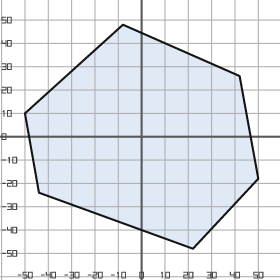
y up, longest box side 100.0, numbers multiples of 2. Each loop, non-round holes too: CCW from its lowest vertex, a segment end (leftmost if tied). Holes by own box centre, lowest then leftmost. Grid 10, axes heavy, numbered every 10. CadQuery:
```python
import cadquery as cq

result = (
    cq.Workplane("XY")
    .moveTo(22.0, -48.0)
    .lineTo(50.0, -18.0)
    .lineTo(42.0, 26.0)
    .lineTo(-8.0, 48.0)
    .lineTo(-50.0, 10.0)
    .lineTo(-44.0, -24.0)
    .close()
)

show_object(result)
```